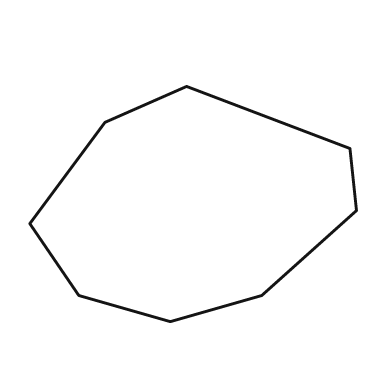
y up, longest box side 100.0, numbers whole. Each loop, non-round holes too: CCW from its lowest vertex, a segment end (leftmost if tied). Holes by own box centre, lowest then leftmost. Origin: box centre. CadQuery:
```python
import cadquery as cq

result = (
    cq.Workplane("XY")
    .moveTo(-7.0, -36.0)
    .lineTo(21.0, -28.0)
    .lineTo(50.0, -2.0)
    .lineTo(48.0, 17.0)
    .lineTo(-2.0, 36.0)
    .lineTo(-27.0, 25.0)
    .lineTo(-50.0, -6.0)
    .lineTo(-35.0, -28.0)
    .close()
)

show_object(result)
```